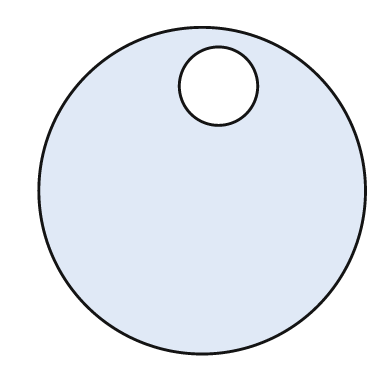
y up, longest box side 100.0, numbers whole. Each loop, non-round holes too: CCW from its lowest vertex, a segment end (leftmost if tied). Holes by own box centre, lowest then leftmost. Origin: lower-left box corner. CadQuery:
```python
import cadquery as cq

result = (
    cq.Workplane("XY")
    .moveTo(50.0, 50.0)
    .circle(50.0)
    .moveTo(55.0, 82.0)
    .circle(12.0)
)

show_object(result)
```